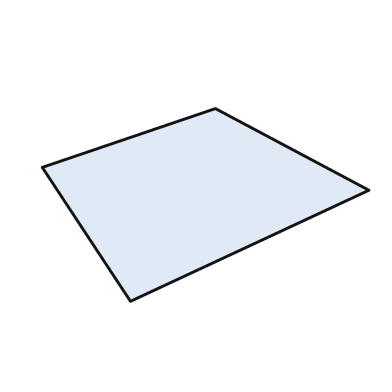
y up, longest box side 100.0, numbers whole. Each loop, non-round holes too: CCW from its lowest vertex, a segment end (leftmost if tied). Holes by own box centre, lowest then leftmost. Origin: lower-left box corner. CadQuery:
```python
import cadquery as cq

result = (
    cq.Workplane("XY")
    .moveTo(27.0, 0.0)
    .lineTo(100.0, 34.0)
    .lineTo(53.0, 59.0)
    .lineTo(0.0, 41.0)
    .close()
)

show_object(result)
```